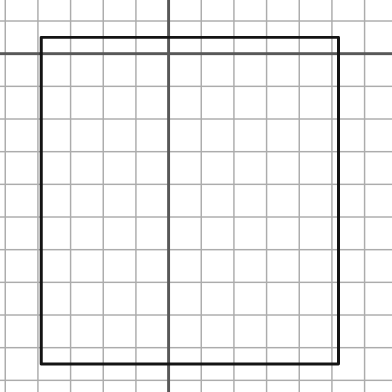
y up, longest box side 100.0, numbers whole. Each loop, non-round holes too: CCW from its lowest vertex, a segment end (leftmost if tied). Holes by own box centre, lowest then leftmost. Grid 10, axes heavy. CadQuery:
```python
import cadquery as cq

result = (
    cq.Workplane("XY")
    .moveTo(-39.0, -95.0)
    .lineTo(52.0, -95.0)
    .lineTo(52.0, 5.0)
    .lineTo(-39.0, 5.0)
    .close()
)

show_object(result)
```